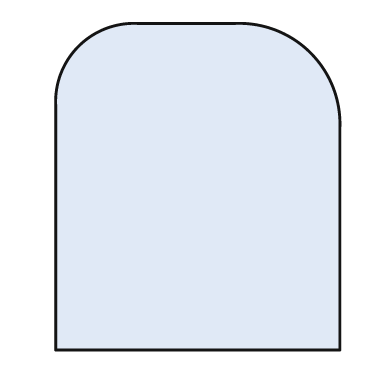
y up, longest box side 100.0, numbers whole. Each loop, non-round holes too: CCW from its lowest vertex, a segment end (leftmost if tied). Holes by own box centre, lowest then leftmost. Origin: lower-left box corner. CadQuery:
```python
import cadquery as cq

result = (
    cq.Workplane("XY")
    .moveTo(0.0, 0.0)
    .lineTo(87.0, 0.0)
    .lineTo(87.0, 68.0)
    .threePointArc((78.0, 91.0), (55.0, 100.0))
    .lineTo(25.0, 100.0)
    .threePointArc((7.0, 93.0), (0.0, 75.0))
    .close()
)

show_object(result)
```